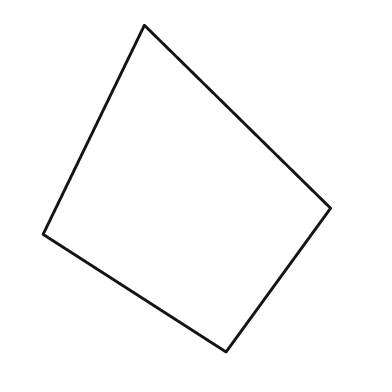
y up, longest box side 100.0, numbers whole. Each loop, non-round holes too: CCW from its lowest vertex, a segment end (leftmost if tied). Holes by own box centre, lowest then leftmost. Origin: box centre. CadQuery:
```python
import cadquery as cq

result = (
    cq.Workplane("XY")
    .moveTo(12.0, -50.0)
    .lineTo(44.0, -6.0)
    .lineTo(-13.0, 50.0)
    .lineTo(-44.0, -14.0)
    .close()
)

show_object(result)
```